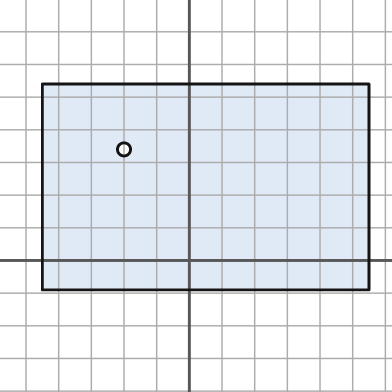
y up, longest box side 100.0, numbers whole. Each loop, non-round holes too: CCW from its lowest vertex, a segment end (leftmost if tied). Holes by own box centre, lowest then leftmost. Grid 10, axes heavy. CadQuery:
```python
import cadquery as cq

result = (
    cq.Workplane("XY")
    .moveTo(-45.0, -9.0)
    .lineTo(55.0, -9.0)
    .lineTo(55.0, 54.0)
    .lineTo(-45.0, 54.0)
    .close()
    .moveTo(-20.0, 34.0)
    .circle(2.0)
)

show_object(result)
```